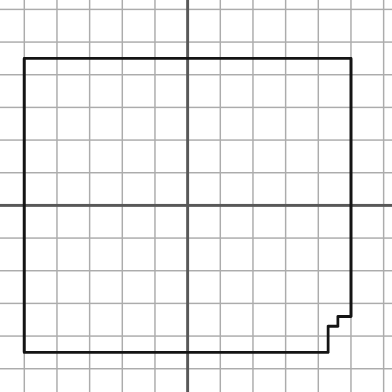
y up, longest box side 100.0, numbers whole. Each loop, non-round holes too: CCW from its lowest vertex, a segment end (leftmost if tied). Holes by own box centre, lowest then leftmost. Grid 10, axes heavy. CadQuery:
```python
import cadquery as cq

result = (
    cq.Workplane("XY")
    .moveTo(-50.0, -45.0)
    .lineTo(43.0, -45.0)
    .lineTo(43.0, -37.0)
    .lineTo(46.0, -37.0)
    .lineTo(46.0, -34.0)
    .lineTo(50.0, -34.0)
    .lineTo(50.0, 45.0)
    .lineTo(-50.0, 45.0)
    .close()
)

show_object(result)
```